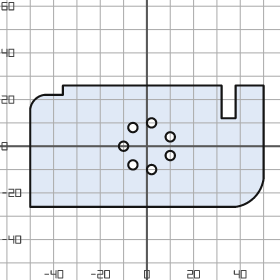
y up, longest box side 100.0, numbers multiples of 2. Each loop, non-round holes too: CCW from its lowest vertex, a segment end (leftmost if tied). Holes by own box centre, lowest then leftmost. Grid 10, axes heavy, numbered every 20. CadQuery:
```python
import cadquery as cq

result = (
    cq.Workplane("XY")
    .moveTo(-50.0, -26.0)
    .lineTo(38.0, -26.0)
    .threePointArc((46.0, -22.0), (50.0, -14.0))
    .lineTo(50.0, 26.0)
    .lineTo(38.0, 26.0)
    .lineTo(38.0, 12.0)
    .lineTo(32.0, 12.0)
    .lineTo(32.0, 26.0)
    .lineTo(-36.0, 26.0)
    .lineTo(-36.0, 22.0)
    .lineTo(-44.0, 22.0)
    .threePointArc((-48.0, 20.0), (-50.0, 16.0))
    .close()
    .moveTo(2.0, -10.0)
    .circle(2.0)
    .moveTo(-6.0, -8.0)
    .circle(2.0)
    .moveTo(10.0, -4.0)
    .circle(2.0)
    .moveTo(-10.0, 0.0)
    .circle(2.0)
    .moveTo(10.0, 4.0)
    .circle(2.0)
    .moveTo(-6.0, 8.0)
    .circle(2.0)
    .moveTo(2.0, 10.0)
    .circle(2.0)
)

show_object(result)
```